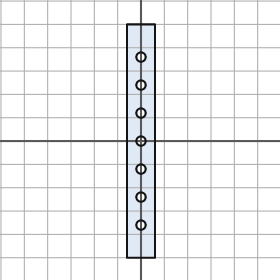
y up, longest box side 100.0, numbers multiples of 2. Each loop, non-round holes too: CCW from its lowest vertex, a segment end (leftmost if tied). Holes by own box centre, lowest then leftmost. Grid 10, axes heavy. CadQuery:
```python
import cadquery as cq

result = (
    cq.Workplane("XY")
    .moveTo(-6.0, -50.0)
    .lineTo(6.0, -50.0)
    .lineTo(6.0, 50.0)
    .lineTo(-6.0, 50.0)
    .close()
    .moveTo(0.0, -36.0)
    .circle(2.0)
    .moveTo(0.0, -24.0)
    .circle(2.0)
    .moveTo(0.0, -12.0)
    .circle(2.0)
    .moveTo(0.0, 0.0)
    .circle(2.0)
    .moveTo(0.0, 12.0)
    .circle(2.0)
    .moveTo(0.0, 24.0)
    .circle(2.0)
    .moveTo(0.0, 36.0)
    .circle(2.0)
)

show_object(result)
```